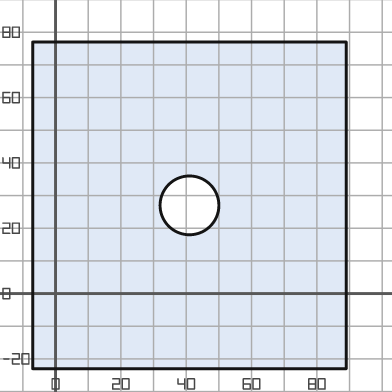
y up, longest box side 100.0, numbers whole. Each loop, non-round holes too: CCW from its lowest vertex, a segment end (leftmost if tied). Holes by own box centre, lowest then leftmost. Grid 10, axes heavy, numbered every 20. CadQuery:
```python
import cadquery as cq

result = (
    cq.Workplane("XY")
    .moveTo(-7.0, -23.0)
    .lineTo(89.0, -23.0)
    .lineTo(89.0, 77.0)
    .lineTo(-7.0, 77.0)
    .close()
    .moveTo(41.0, 27.0)
    .circle(9.0)
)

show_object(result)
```